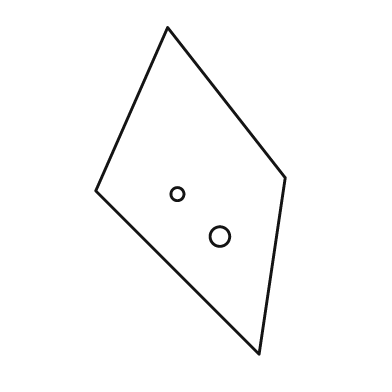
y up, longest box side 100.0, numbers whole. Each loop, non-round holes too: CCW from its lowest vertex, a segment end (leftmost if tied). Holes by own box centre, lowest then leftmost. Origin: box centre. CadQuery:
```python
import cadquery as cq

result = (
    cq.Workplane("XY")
    .moveTo(21.0, -50.0)
    .lineTo(29.0, 4.0)
    .lineTo(-7.0, 50.0)
    .lineTo(-29.0, 0.0)
    .close()
    .moveTo(9.0, -14.0)
    .circle(3.0)
    .moveTo(-4.0, -1.0)
    .circle(2.0)
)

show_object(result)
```